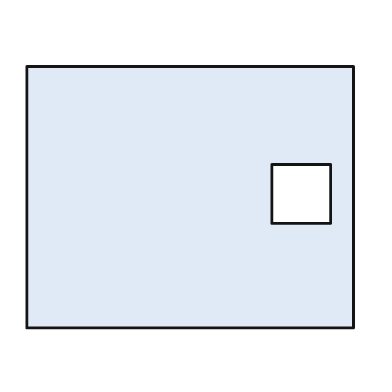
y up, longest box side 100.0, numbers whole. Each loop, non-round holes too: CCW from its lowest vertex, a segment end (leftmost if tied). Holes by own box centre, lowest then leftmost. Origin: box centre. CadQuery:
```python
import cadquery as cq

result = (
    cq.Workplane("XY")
    .moveTo(-50.0, -40.0)
    .lineTo(50.0, -40.0)
    .lineTo(50.0, 40.0)
    .lineTo(-50.0, 40.0)
    .close()
    .moveTo(25.0, -8.0)
    .lineTo(43.0, -8.0)
    .lineTo(43.0, 10.0)
    .lineTo(25.0, 10.0)
    .close()
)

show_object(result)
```